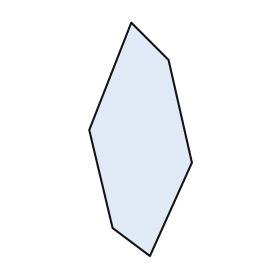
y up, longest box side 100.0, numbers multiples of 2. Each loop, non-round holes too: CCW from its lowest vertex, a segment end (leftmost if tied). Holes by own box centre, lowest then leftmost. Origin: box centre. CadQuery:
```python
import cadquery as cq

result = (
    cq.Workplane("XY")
    .moveTo(4.0, -50.0)
    .lineTo(22.0, -10.0)
    .lineTo(12.0, 34.0)
    .lineTo(-4.0, 50.0)
    .lineTo(-22.0, 4.0)
    .lineTo(-12.0, -38.0)
    .close()
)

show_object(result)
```